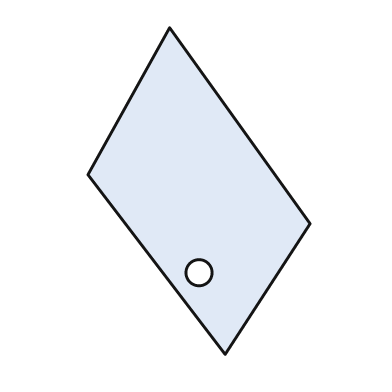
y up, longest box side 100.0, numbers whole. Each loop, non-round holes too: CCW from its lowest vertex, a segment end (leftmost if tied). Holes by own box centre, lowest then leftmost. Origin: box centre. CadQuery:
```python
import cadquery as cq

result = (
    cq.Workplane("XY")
    .moveTo(8.0, -50.0)
    .lineTo(34.0, -10.0)
    .lineTo(-9.0, 50.0)
    .lineTo(-34.0, 5.0)
    .close()
    .moveTo(0.0, -25.0)
    .circle(4.0)
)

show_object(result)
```